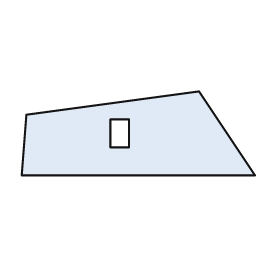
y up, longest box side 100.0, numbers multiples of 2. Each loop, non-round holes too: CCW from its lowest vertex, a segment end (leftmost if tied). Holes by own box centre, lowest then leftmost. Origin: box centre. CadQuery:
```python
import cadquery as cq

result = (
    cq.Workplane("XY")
    .moveTo(-50.0, -18.0)
    .lineTo(50.0, -18.0)
    .lineTo(26.0, 18.0)
    .lineTo(-48.0, 8.0)
    .close()
    .moveTo(-12.0, -6.0)
    .lineTo(-4.0, -6.0)
    .lineTo(-4.0, 6.0)
    .lineTo(-12.0, 6.0)
    .close()
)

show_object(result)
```